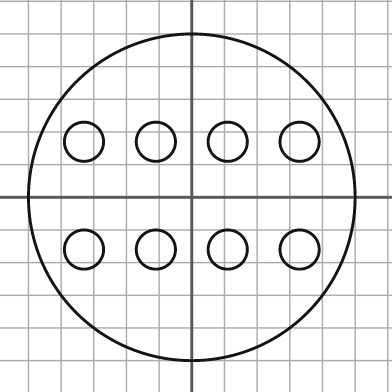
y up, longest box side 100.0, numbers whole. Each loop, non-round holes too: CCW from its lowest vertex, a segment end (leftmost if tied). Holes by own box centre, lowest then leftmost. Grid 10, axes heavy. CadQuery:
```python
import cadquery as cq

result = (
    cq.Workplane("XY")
    .moveTo(0.0, 0.0)
    .circle(50.0)
    .moveTo(-33.0, -16.0)
    .circle(6.0)
    .moveTo(-11.0, -16.0)
    .circle(6.0)
    .moveTo(11.0, -16.0)
    .circle(6.0)
    .moveTo(33.0, -16.0)
    .circle(6.0)
    .moveTo(-33.0, 17.0)
    .circle(6.0)
    .moveTo(-11.0, 17.0)
    .circle(6.0)
    .moveTo(11.0, 17.0)
    .circle(6.0)
    .moveTo(33.0, 17.0)
    .circle(6.0)
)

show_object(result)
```